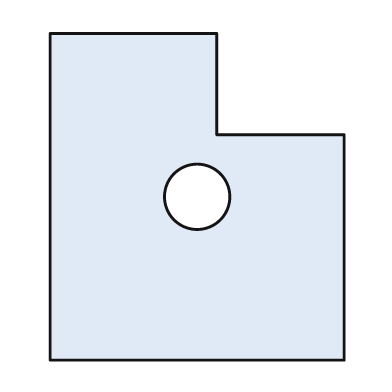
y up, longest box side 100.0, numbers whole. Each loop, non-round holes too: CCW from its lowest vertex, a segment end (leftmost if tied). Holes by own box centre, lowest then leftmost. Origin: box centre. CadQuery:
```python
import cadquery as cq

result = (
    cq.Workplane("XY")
    .moveTo(-45.0, -50.0)
    .lineTo(45.0, -50.0)
    .lineTo(45.0, 19.0)
    .lineTo(6.0, 19.0)
    .lineTo(6.0, 50.0)
    .lineTo(-45.0, 50.0)
    .close()
    .moveTo(0.0, 0.0)
    .circle(10.0)
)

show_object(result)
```